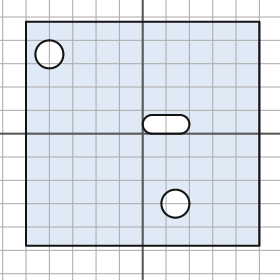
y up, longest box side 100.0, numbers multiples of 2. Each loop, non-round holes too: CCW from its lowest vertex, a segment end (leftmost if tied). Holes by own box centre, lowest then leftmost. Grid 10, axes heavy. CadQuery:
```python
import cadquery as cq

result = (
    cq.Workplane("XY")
    .moveTo(-50.0, -48.0)
    .lineTo(50.0, -48.0)
    .lineTo(50.0, 48.0)
    .lineTo(-50.0, 48.0)
    .close()
    .moveTo(14.0, -30.0)
    .circle(6.0)
    .moveTo(4.0, 0.0)
    .lineTo(16.0, 0.0)
    .threePointArc((20.0, 4.0), (16.0, 8.0))
    .lineTo(4.0, 8.0)
    .threePointArc((0.0, 4.0), (4.0, 0.0))
    .close()
    .moveTo(-40.0, 34.0)
    .circle(6.0)
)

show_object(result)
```